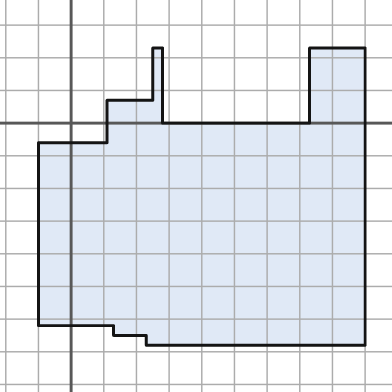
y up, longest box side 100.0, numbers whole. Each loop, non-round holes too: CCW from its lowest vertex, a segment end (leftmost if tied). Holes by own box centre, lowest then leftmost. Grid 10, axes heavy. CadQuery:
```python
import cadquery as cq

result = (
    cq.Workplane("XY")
    .moveTo(23.0, -68.0)
    .lineTo(90.0, -68.0)
    .lineTo(90.0, 23.0)
    .lineTo(73.0, 23.0)
    .lineTo(73.0, 0.0)
    .lineTo(28.0, 0.0)
    .lineTo(28.0, 23.0)
    .lineTo(25.0, 23.0)
    .lineTo(25.0, 7.0)
    .lineTo(11.0, 7.0)
    .lineTo(11.0, -6.0)
    .lineTo(-10.0, -6.0)
    .lineTo(-10.0, -62.0)
    .lineTo(13.0, -62.0)
    .lineTo(13.0, -65.0)
    .lineTo(23.0, -65.0)
    .close()
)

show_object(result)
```